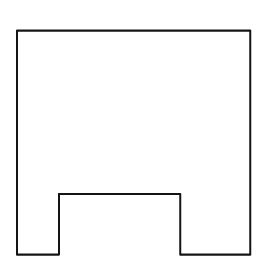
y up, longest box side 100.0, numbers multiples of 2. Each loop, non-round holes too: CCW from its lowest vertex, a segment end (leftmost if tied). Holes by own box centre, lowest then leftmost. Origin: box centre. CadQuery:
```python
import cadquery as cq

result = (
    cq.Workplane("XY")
    .moveTo(-50.0, -48.0)
    .lineTo(-32.0, -48.0)
    .lineTo(-32.0, -22.0)
    .lineTo(20.0, -22.0)
    .lineTo(20.0, -48.0)
    .lineTo(50.0, -48.0)
    .lineTo(50.0, 48.0)
    .lineTo(-50.0, 48.0)
    .close()
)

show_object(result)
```